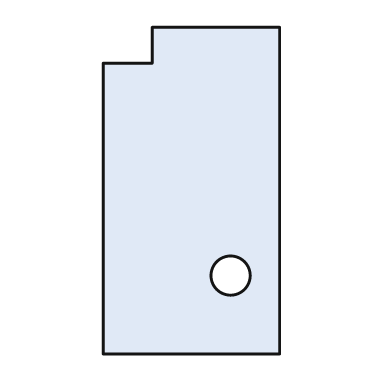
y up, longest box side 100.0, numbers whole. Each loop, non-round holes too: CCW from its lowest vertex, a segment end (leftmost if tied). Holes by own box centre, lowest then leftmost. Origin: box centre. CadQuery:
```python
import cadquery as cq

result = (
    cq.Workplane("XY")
    .moveTo(-27.0, -50.0)
    .lineTo(27.0, -50.0)
    .lineTo(27.0, 50.0)
    .lineTo(-12.0, 50.0)
    .lineTo(-12.0, 39.0)
    .lineTo(-27.0, 39.0)
    .close()
    .moveTo(12.0, -26.0)
    .circle(6.0)
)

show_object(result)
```